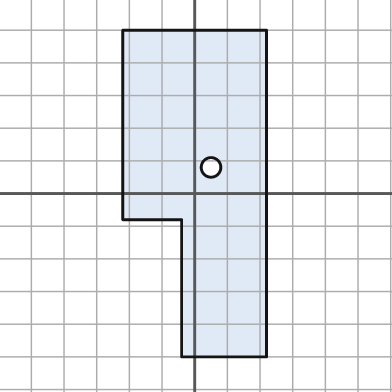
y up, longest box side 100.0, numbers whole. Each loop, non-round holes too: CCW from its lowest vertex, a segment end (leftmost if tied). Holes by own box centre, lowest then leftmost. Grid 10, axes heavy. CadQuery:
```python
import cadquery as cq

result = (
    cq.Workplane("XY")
    .moveTo(-4.0, -50.0)
    .lineTo(22.0, -50.0)
    .lineTo(22.0, 50.0)
    .lineTo(-22.0, 50.0)
    .lineTo(-22.0, -8.0)
    .lineTo(-4.0, -8.0)
    .close()
    .moveTo(5.0, 8.0)
    .circle(3.0)
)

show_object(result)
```